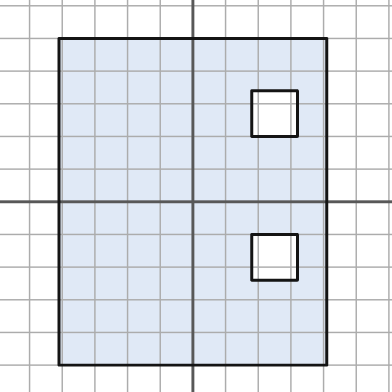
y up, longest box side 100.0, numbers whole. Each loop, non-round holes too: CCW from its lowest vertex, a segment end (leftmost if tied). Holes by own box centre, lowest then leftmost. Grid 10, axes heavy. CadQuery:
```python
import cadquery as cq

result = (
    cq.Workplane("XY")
    .moveTo(-41.0, -50.0)
    .lineTo(41.0, -50.0)
    .lineTo(41.0, 50.0)
    .lineTo(-41.0, 50.0)
    .close()
    .moveTo(18.0, -24.0)
    .lineTo(32.0, -24.0)
    .lineTo(32.0, -10.0)
    .lineTo(18.0, -10.0)
    .close()
    .moveTo(18.0, 20.0)
    .lineTo(32.0, 20.0)
    .lineTo(32.0, 34.0)
    .lineTo(18.0, 34.0)
    .close()
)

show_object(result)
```